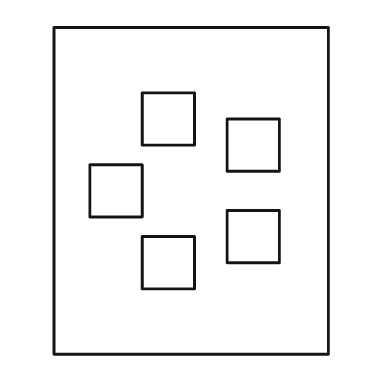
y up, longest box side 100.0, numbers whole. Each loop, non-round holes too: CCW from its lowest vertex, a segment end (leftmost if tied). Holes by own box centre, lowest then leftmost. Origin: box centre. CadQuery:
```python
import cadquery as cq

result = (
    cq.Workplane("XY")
    .moveTo(-42.0, -50.0)
    .lineTo(42.0, -50.0)
    .lineTo(42.0, 50.0)
    .lineTo(-42.0, 50.0)
    .close()
    .moveTo(-15.0, -30.0)
    .lineTo(1.0, -30.0)
    .lineTo(1.0, -14.0)
    .lineTo(-15.0, -14.0)
    .close()
    .moveTo(11.0, -22.0)
    .lineTo(27.0, -22.0)
    .lineTo(27.0, -6.0)
    .lineTo(11.0, -6.0)
    .close()
    .moveTo(-31.0, -8.0)
    .lineTo(-15.0, -8.0)
    .lineTo(-15.0, 8.0)
    .lineTo(-31.0, 8.0)
    .close()
    .moveTo(11.0, 6.0)
    .lineTo(27.0, 6.0)
    .lineTo(27.0, 22.0)
    .lineTo(11.0, 22.0)
    .close()
    .moveTo(-15.0, 14.0)
    .lineTo(1.0, 14.0)
    .lineTo(1.0, 30.0)
    .lineTo(-15.0, 30.0)
    .close()
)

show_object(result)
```